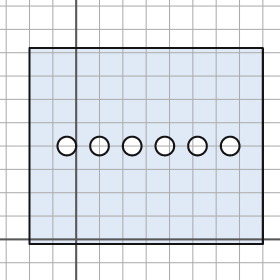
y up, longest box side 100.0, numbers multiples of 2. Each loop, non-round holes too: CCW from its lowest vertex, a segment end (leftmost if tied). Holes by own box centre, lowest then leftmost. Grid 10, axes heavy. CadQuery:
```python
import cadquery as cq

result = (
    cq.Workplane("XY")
    .moveTo(-20.0, -2.0)
    .lineTo(80.0, -2.0)
    .lineTo(80.0, 82.0)
    .lineTo(-20.0, 82.0)
    .close()
    .moveTo(-4.0, 40.0)
    .circle(4.0)
    .moveTo(10.0, 40.0)
    .circle(4.0)
    .moveTo(24.0, 40.0)
    .circle(4.0)
    .moveTo(38.0, 40.0)
    .circle(4.0)
    .moveTo(52.0, 40.0)
    .circle(4.0)
    .moveTo(66.0, 40.0)
    .circle(4.0)
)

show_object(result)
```